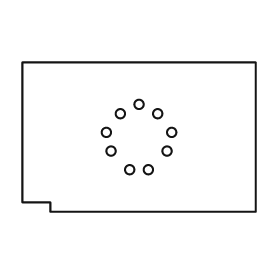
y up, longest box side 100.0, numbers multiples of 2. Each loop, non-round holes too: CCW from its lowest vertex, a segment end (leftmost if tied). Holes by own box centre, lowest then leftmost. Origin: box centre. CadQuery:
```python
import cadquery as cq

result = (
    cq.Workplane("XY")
    .moveTo(-38.0, -32.0)
    .lineTo(50.0, -32.0)
    .lineTo(50.0, 32.0)
    .lineTo(-50.0, 32.0)
    .lineTo(-50.0, -28.0)
    .lineTo(-38.0, -28.0)
    .close()
    .moveTo(-4.0, -14.0)
    .circle(2.0)
    .moveTo(4.0, -14.0)
    .circle(2.0)
    .moveTo(-12.0, -6.0)
    .circle(2.0)
    .moveTo(12.0, -6.0)
    .circle(2.0)
    .moveTo(-14.0, 2.0)
    .circle(2.0)
    .moveTo(14.0, 2.0)
    .circle(2.0)
    .moveTo(-8.0, 10.0)
    .circle(2.0)
    .moveTo(8.0, 10.0)
    .circle(2.0)
    .moveTo(0.0, 14.0)
    .circle(2.0)
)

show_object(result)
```